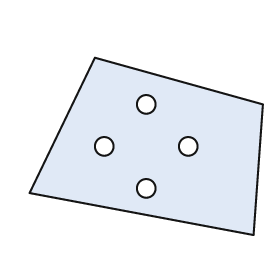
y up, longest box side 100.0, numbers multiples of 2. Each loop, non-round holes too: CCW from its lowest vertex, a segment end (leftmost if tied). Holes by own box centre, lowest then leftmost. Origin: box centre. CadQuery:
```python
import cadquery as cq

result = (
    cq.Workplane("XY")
    .moveTo(46.0, -38.0)
    .lineTo(50.0, 18.0)
    .lineTo(-22.0, 38.0)
    .lineTo(-50.0, -20.0)
    .close()
    .moveTo(0.0, -18.0)
    .circle(4.0)
    .moveTo(-18.0, 0.0)
    .circle(4.0)
    .moveTo(18.0, 0.0)
    .circle(4.0)
    .moveTo(0.0, 18.0)
    .circle(4.0)
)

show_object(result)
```